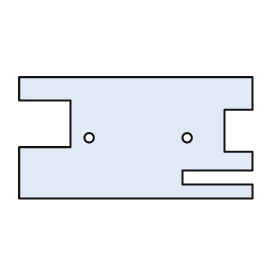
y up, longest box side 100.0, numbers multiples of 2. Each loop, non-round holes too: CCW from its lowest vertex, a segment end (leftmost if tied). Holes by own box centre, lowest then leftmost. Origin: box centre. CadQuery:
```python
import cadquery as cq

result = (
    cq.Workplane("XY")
    .moveTo(-50.0, -26.0)
    .lineTo(50.0, -26.0)
    .lineTo(50.0, -20.0)
    .lineTo(20.0, -20.0)
    .lineTo(20.0, -14.0)
    .lineTo(50.0, -14.0)
    .lineTo(50.0, -6.0)
    .lineTo(38.0, -6.0)
    .lineTo(38.0, 12.0)
    .lineTo(50.0, 12.0)
    .lineTo(50.0, 26.0)
    .lineTo(-50.0, 26.0)
    .lineTo(-50.0, 16.0)
    .lineTo(-28.0, 16.0)
    .lineTo(-28.0, -4.0)
    .lineTo(-50.0, -4.0)
    .close()
    .moveTo(-20.0, 0.0)
    .circle(2.0)
    .moveTo(22.0, 0.0)
    .circle(2.0)
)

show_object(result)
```